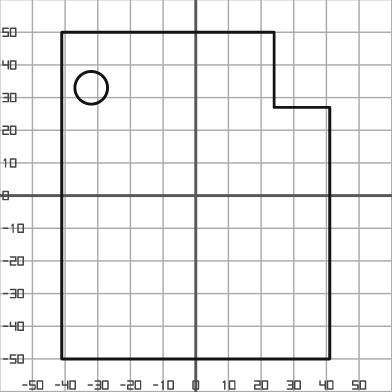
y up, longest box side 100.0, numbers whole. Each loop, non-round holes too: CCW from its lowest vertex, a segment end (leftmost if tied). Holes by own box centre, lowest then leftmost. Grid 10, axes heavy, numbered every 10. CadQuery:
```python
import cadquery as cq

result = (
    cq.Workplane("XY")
    .moveTo(-41.0, -50.0)
    .lineTo(41.0, -50.0)
    .lineTo(41.0, 27.0)
    .lineTo(24.0, 27.0)
    .lineTo(24.0, 50.0)
    .lineTo(-41.0, 50.0)
    .close()
    .moveTo(-32.0, 33.0)
    .circle(5.0)
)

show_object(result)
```